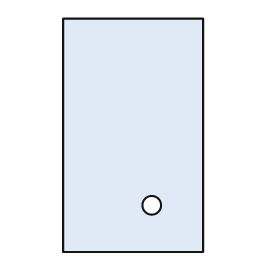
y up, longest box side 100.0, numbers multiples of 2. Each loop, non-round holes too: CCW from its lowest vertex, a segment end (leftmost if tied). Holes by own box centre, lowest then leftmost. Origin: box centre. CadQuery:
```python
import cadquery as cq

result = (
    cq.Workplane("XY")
    .moveTo(-30.0, -50.0)
    .lineTo(30.0, -50.0)
    .lineTo(30.0, 50.0)
    .lineTo(-30.0, 50.0)
    .close()
    .moveTo(8.0, -30.0)
    .circle(4.0)
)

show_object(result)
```